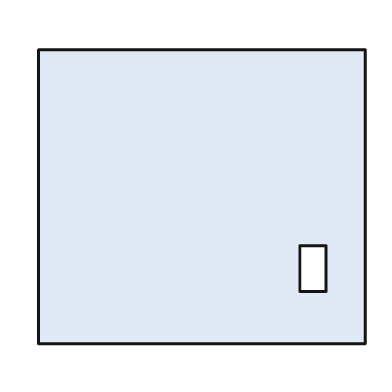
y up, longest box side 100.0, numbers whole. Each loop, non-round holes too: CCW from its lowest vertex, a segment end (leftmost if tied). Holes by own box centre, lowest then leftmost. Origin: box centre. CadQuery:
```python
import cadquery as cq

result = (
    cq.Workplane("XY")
    .moveTo(-50.0, -45.0)
    .lineTo(50.0, -45.0)
    .lineTo(50.0, 45.0)
    .lineTo(-50.0, 45.0)
    .close()
    .moveTo(30.0, -29.0)
    .lineTo(38.0, -29.0)
    .lineTo(38.0, -15.0)
    .lineTo(30.0, -15.0)
    .close()
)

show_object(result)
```